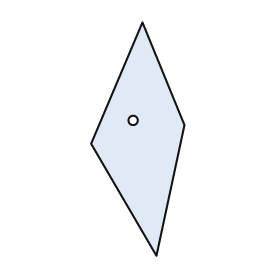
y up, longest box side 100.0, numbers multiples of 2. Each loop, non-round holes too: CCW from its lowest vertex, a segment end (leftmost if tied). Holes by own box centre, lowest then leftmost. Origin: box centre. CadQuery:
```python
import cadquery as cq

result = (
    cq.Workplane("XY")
    .moveTo(8.0, -50.0)
    .lineTo(20.0, 6.0)
    .lineTo(2.0, 50.0)
    .lineTo(-20.0, -2.0)
    .close()
    .moveTo(-2.0, 8.0)
    .circle(2.0)
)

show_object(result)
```